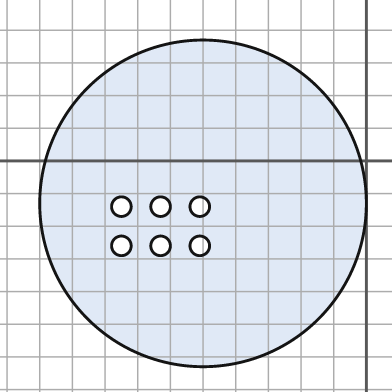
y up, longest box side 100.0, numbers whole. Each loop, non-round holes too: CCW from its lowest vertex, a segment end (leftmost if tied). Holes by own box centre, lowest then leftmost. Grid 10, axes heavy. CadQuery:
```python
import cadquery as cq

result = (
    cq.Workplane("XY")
    .moveTo(-50.0, -13.0)
    .circle(50.0)
    .moveTo(-75.0, -26.0)
    .circle(3.0)
    .moveTo(-63.0, -26.0)
    .circle(3.0)
    .moveTo(-51.0, -26.0)
    .circle(3.0)
    .moveTo(-75.0, -14.0)
    .circle(3.0)
    .moveTo(-63.0, -14.0)
    .circle(3.0)
    .moveTo(-51.0, -14.0)
    .circle(3.0)
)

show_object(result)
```